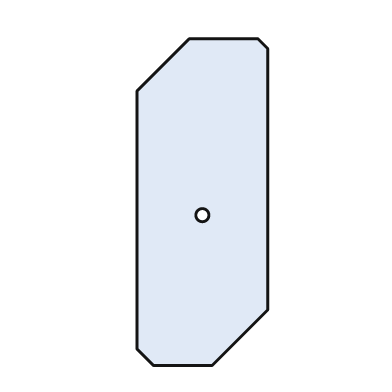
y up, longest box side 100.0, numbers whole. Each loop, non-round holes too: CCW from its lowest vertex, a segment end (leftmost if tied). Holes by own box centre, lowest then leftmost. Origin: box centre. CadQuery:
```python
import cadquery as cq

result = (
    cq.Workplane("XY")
    .moveTo(-15.0, -50.0)
    .lineTo(3.0, -50.0)
    .lineTo(20.0, -33.0)
    .lineTo(20.0, 47.0)
    .lineTo(17.0, 50.0)
    .lineTo(-4.0, 50.0)
    .lineTo(-20.0, 34.0)
    .lineTo(-20.0, -45.0)
    .close()
    .moveTo(0.0, -4.0)
    .circle(2.0)
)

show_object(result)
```